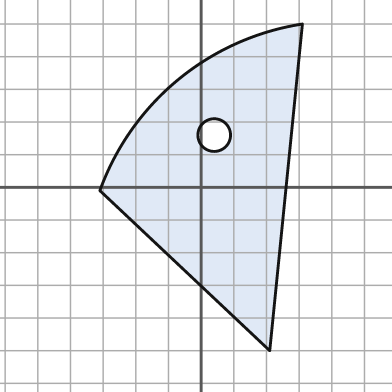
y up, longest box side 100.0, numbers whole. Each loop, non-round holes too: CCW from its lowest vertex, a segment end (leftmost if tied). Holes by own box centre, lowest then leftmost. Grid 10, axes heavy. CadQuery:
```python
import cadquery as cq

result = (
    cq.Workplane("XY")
    .moveTo(21.0, -50.0)
    .lineTo(31.0, 50.0)
    .threePointArc((-7.0, 33.0), (-31.0, -1.0))
    .close()
    .moveTo(4.0, 16.0)
    .circle(5.0)
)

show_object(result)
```